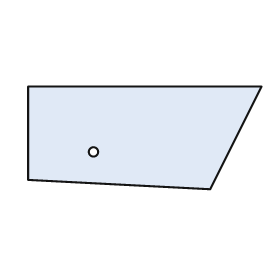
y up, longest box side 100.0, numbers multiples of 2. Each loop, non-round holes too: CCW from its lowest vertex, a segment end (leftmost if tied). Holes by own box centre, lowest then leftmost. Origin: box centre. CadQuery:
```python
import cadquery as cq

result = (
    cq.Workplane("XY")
    .moveTo(28.0, -22.0)
    .lineTo(50.0, 22.0)
    .lineTo(-50.0, 22.0)
    .lineTo(-50.0, -18.0)
    .close()
    .moveTo(-22.0, -6.0)
    .circle(2.0)
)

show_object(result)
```